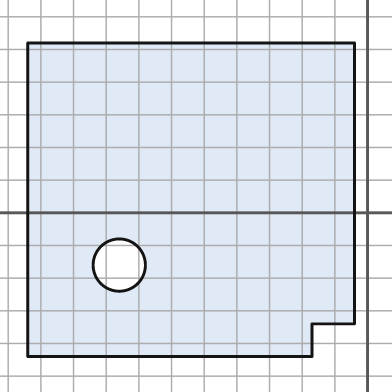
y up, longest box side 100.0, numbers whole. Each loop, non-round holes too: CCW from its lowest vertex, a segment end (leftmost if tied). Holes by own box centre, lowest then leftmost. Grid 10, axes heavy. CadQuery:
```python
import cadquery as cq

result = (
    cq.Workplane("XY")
    .moveTo(-104.0, -44.0)
    .lineTo(-17.0, -44.0)
    .lineTo(-17.0, -34.0)
    .lineTo(-4.0, -34.0)
    .lineTo(-4.0, 52.0)
    .lineTo(-104.0, 52.0)
    .close()
    .moveTo(-76.0, -16.0)
    .circle(8.0)
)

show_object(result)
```